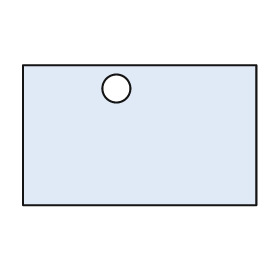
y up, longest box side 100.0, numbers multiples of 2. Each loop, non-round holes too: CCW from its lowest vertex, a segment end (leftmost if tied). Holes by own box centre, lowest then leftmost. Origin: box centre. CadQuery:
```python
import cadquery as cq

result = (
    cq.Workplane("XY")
    .moveTo(-50.0, -30.0)
    .lineTo(50.0, -30.0)
    .lineTo(50.0, 30.0)
    .lineTo(-50.0, 30.0)
    .close()
    .moveTo(-10.0, 20.0)
    .circle(6.0)
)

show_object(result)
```